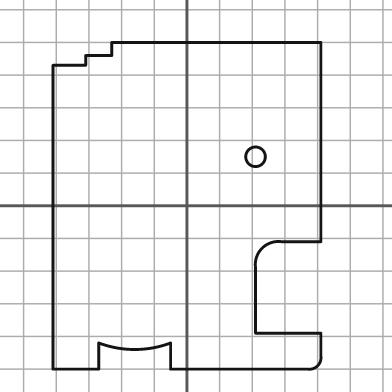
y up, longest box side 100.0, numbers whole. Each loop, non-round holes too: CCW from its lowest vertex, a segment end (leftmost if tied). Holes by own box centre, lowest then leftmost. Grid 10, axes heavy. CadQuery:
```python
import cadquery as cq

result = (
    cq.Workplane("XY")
    .moveTo(-41.0, -50.0)
    .lineTo(-27.0, -50.0)
    .lineTo(-27.0, -42.0)
    .threePointArc((-16.0, -44.0), (-5.0, -42.0))
    .lineTo(-5.0, -50.0)
    .lineTo(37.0, -50.0)
    .threePointArc((40.0, -49.0), (41.0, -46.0))
    .lineTo(41.0, -39.0)
    .lineTo(21.0, -39.0)
    .lineTo(21.0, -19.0)
    .threePointArc((23.0, -13.0), (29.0, -11.0))
    .lineTo(41.0, -11.0)
    .lineTo(41.0, 50.0)
    .lineTo(-23.0, 50.0)
    .lineTo(-23.0, 46.0)
    .lineTo(-31.0, 46.0)
    .lineTo(-31.0, 43.0)
    .lineTo(-41.0, 43.0)
    .close()
    .moveTo(21.0, 15.0)
    .circle(3.0)
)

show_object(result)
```